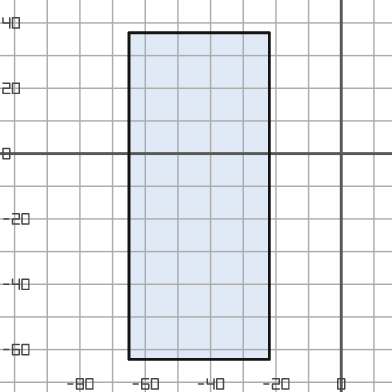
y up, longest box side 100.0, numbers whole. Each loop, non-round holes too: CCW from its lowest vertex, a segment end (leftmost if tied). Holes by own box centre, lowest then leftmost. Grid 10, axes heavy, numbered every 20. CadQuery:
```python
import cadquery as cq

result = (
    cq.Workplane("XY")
    .moveTo(-65.0, -63.0)
    .lineTo(-22.0, -63.0)
    .lineTo(-22.0, 37.0)
    .lineTo(-65.0, 37.0)
    .close()
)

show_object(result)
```